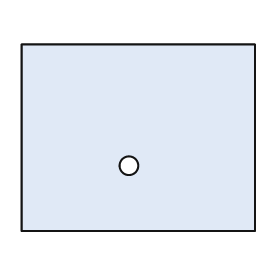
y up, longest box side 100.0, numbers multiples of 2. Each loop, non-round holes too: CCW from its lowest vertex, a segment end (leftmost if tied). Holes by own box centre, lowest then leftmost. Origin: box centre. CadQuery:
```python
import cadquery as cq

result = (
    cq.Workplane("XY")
    .moveTo(-50.0, -40.0)
    .lineTo(50.0, -40.0)
    .lineTo(50.0, 40.0)
    .lineTo(-50.0, 40.0)
    .close()
    .moveTo(-4.0, -12.0)
    .circle(4.0)
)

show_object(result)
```